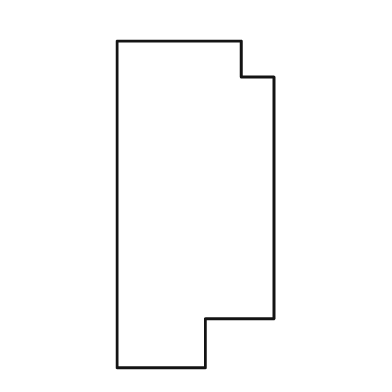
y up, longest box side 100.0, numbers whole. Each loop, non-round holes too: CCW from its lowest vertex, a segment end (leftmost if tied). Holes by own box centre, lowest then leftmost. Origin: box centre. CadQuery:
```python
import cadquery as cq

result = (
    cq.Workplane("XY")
    .moveTo(-24.0, -50.0)
    .lineTo(3.0, -50.0)
    .lineTo(3.0, -35.0)
    .lineTo(24.0, -35.0)
    .lineTo(24.0, 39.0)
    .lineTo(14.0, 39.0)
    .lineTo(14.0, 50.0)
    .lineTo(-24.0, 50.0)
    .close()
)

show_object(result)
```